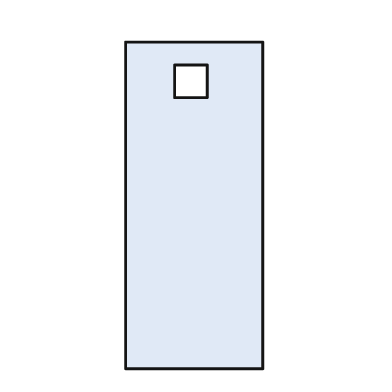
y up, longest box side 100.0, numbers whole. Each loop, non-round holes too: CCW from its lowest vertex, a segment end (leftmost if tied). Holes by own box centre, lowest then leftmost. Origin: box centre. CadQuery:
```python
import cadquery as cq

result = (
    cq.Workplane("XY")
    .moveTo(-21.0, -50.0)
    .lineTo(21.0, -50.0)
    .lineTo(21.0, 50.0)
    .lineTo(-21.0, 50.0)
    .close()
    .moveTo(-6.0, 33.0)
    .lineTo(4.0, 33.0)
    .lineTo(4.0, 43.0)
    .lineTo(-6.0, 43.0)
    .close()
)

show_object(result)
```